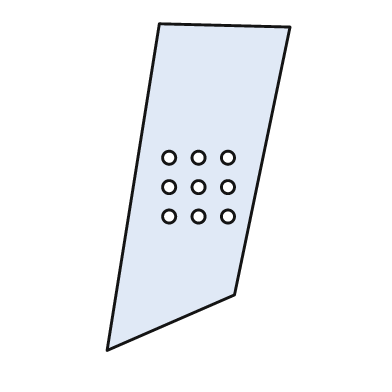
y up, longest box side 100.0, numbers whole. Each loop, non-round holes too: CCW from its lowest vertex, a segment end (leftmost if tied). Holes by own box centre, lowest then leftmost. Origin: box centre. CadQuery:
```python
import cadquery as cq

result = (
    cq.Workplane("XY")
    .moveTo(-28.0, -50.0)
    .lineTo(11.0, -33.0)
    .lineTo(28.0, 49.0)
    .lineTo(-12.0, 50.0)
    .close()
    .moveTo(-9.0, -9.0)
    .circle(2.0)
    .moveTo(0.0, -9.0)
    .circle(2.0)
    .moveTo(9.0, -9.0)
    .circle(2.0)
    .moveTo(-9.0, 0.0)
    .circle(2.0)
    .moveTo(0.0, 0.0)
    .circle(2.0)
    .moveTo(9.0, 0.0)
    .circle(2.0)
    .moveTo(-9.0, 9.0)
    .circle(2.0)
    .moveTo(0.0, 9.0)
    .circle(2.0)
    .moveTo(9.0, 9.0)
    .circle(2.0)
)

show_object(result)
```